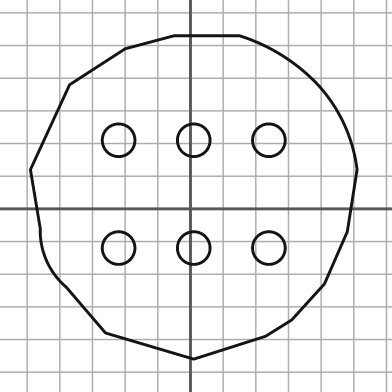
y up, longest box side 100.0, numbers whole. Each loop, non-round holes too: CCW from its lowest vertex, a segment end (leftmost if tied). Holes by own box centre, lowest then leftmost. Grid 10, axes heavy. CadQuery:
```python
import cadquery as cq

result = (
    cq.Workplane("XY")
    .moveTo(1.0, -46.0)
    .lineTo(23.0, -39.0)
    .lineTo(31.0, -34.0)
    .lineTo(41.0, -23.0)
    .lineTo(48.0, -7.0)
    .lineTo(51.0, 12.0)
    .threePointArc((47.0, 26.0), (39.0, 38.0))
    .threePointArc((28.0, 47.0), (15.0, 53.0))
    .lineTo(-5.0, 53.0)
    .lineTo(-20.0, 49.0)
    .lineTo(-37.0, 38.0)
    .lineTo(-49.0, 12.0)
    .lineTo(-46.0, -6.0)
    .threePointArc((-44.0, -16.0), (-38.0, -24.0))
    .lineTo(-26.0, -38.0)
    .close()
    .moveTo(-22.0, -12.0)
    .circle(5.0)
    .moveTo(1.0, -12.0)
    .circle(5.0)
    .moveTo(24.0, -12.0)
    .circle(5.0)
    .moveTo(-22.0, 21.0)
    .circle(5.0)
    .moveTo(1.0, 21.0)
    .circle(5.0)
    .moveTo(24.0, 21.0)
    .circle(5.0)
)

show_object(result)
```